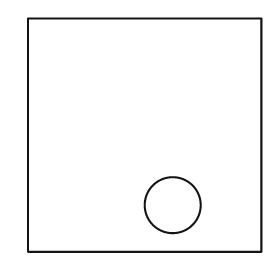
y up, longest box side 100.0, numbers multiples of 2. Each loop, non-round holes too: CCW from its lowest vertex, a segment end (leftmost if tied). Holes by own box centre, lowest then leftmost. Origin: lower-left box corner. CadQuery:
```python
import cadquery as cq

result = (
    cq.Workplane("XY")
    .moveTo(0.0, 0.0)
    .lineTo(100.0, 0.0)
    .lineTo(100.0, 100.0)
    .lineTo(0.0, 100.0)
    .close()
    .moveTo(62.0, 20.0)
    .circle(12.0)
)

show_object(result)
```